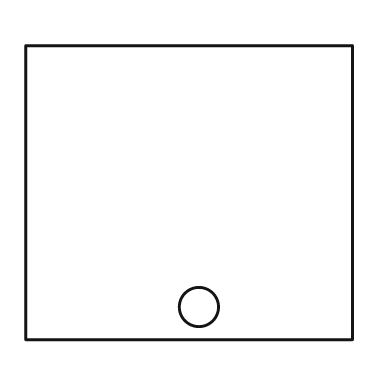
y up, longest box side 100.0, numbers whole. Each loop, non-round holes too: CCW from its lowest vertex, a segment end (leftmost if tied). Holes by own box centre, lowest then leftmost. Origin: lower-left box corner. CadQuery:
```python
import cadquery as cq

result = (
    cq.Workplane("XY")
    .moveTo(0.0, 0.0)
    .lineTo(100.0, 0.0)
    .lineTo(100.0, 90.0)
    .lineTo(0.0, 90.0)
    .close()
    .moveTo(53.0, 10.0)
    .circle(6.0)
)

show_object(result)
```